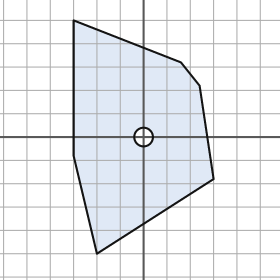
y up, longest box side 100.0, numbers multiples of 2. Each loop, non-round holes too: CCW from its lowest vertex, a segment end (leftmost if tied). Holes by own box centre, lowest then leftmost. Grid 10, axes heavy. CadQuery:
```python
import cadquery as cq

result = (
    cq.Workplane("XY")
    .moveTo(-20.0, -50.0)
    .lineTo(30.0, -18.0)
    .lineTo(24.0, 22.0)
    .lineTo(16.0, 32.0)
    .lineTo(-30.0, 50.0)
    .lineTo(-30.0, -8.0)
    .close()
    .moveTo(0.0, 0.0)
    .circle(4.0)
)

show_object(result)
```